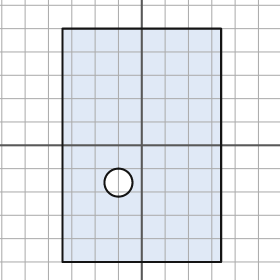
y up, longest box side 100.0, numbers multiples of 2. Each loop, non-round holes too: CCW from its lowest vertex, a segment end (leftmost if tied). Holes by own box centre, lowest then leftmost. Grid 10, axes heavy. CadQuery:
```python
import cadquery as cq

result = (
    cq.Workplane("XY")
    .moveTo(-34.0, -50.0)
    .lineTo(34.0, -50.0)
    .lineTo(34.0, 50.0)
    .lineTo(-34.0, 50.0)
    .close()
    .moveTo(-10.0, -16.0)
    .circle(6.0)
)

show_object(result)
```